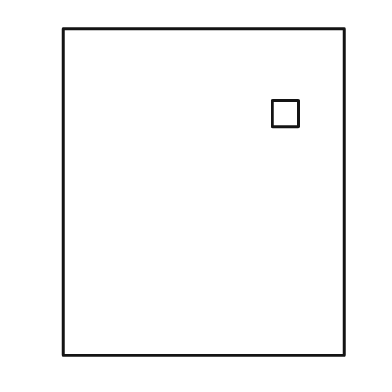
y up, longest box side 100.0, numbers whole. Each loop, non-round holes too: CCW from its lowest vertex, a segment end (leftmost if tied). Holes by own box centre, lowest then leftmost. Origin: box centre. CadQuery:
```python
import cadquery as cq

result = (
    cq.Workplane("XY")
    .moveTo(-43.0, -50.0)
    .lineTo(43.0, -50.0)
    .lineTo(43.0, 50.0)
    .lineTo(-43.0, 50.0)
    .close()
    .moveTo(21.0, 20.0)
    .lineTo(29.0, 20.0)
    .lineTo(29.0, 28.0)
    .lineTo(21.0, 28.0)
    .close()
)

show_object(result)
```